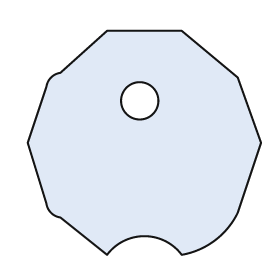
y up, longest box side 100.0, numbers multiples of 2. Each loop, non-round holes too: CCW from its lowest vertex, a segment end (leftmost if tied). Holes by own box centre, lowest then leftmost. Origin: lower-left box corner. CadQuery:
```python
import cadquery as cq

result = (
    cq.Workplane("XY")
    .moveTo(34.0, 0.0)
    .threePointArc((50.0, 8.0), (66.0, 0.0))
    .threePointArc((80.0, 6.0), (90.0, 18.0))
    .lineTo(100.0, 48.0)
    .lineTo(90.0, 76.0)
    .lineTo(66.0, 96.0)
    .lineTo(34.0, 96.0)
    .lineTo(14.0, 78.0)
    .threePointArc((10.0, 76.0), (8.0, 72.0))
    .lineTo(0.0, 48.0)
    .lineTo(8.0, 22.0)
    .threePointArc((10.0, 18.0), (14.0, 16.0))
    .close()
    .moveTo(48.0, 66.0)
    .circle(8.0)
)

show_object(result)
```